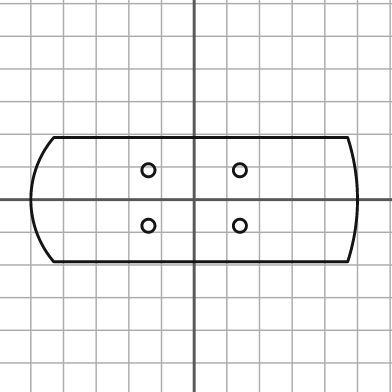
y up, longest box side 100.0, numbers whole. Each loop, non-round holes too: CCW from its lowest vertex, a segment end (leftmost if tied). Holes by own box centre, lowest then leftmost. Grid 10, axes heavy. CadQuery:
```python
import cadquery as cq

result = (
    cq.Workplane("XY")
    .moveTo(-43.0, -19.0)
    .lineTo(47.0, -19.0)
    .threePointArc((50.0, 0.0), (47.0, 19.0))
    .lineTo(-43.0, 19.0)
    .threePointArc((-50.0, 0.0), (-43.0, -19.0))
    .close()
    .moveTo(-14.0, -8.0)
    .circle(2.0)
    .moveTo(14.0, -8.0)
    .circle(2.0)
    .moveTo(-14.0, 9.0)
    .circle(2.0)
    .moveTo(14.0, 9.0)
    .circle(2.0)
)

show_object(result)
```